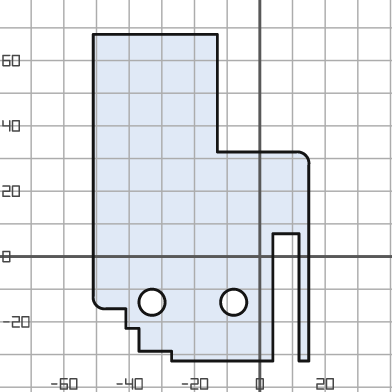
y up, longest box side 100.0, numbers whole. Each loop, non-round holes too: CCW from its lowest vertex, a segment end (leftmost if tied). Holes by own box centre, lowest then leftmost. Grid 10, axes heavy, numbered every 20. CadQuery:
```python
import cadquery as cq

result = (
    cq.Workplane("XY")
    .moveTo(-27.0, -32.0)
    .lineTo(4.0, -32.0)
    .lineTo(4.0, 7.0)
    .lineTo(12.0, 7.0)
    .lineTo(12.0, -32.0)
    .lineTo(15.0, -32.0)
    .lineTo(15.0, 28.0)
    .threePointArc((14.0, 31.0), (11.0, 32.0))
    .lineTo(-13.0, 32.0)
    .lineTo(-13.0, 68.0)
    .lineTo(-51.0, 68.0)
    .lineTo(-51.0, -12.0)
    .threePointArc((-50.0, -15.0), (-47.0, -16.0))
    .lineTo(-41.0, -16.0)
    .lineTo(-41.0, -22.0)
    .lineTo(-37.0, -22.0)
    .lineTo(-37.0, -29.0)
    .lineTo(-27.0, -29.0)
    .close()
    .moveTo(-33.0, -14.0)
    .circle(4.0)
    .moveTo(-8.0, -14.0)
    .circle(4.0)
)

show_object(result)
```